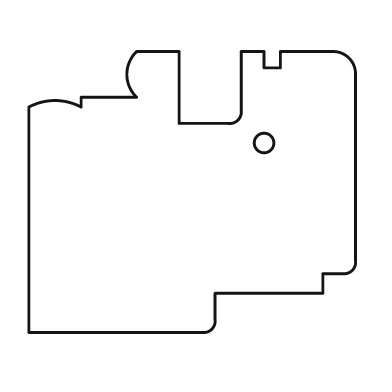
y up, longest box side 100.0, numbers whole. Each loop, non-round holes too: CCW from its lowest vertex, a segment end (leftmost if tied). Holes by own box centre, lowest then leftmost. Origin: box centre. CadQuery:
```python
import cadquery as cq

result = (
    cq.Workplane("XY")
    .moveTo(-50.0, -43.0)
    .lineTo(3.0, -43.0)
    .threePointArc((6.0, -42.0), (7.0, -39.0))
    .lineTo(7.0, -31.0)
    .lineTo(40.0, -31.0)
    .lineTo(40.0, -25.0)
    .lineTo(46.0, -25.0)
    .threePointArc((49.0, -24.0), (50.0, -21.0))
    .lineTo(50.0, 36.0)
    .threePointArc((48.0, 41.0), (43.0, 43.0))
    .lineTo(27.0, 43.0)
    .lineTo(27.0, 38.0)
    .lineTo(22.0, 38.0)
    .lineTo(22.0, 43.0)
    .lineTo(15.0, 43.0)
    .lineTo(15.0, 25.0)
    .threePointArc((14.0, 22.0), (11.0, 21.0))
    .lineTo(-4.0, 21.0)
    .lineTo(-4.0, 43.0)
    .lineTo(-17.0, 43.0)
    .threePointArc((-20.0, 36.0), (-17.0, 29.0))
    .lineTo(-34.0, 29.0)
    .lineTo(-34.0, 26.0)
    .threePointArc((-42.0, 28.0), (-50.0, 26.0))
    .close()
    .moveTo(22.0, 15.0)
    .circle(3.0)
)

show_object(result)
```